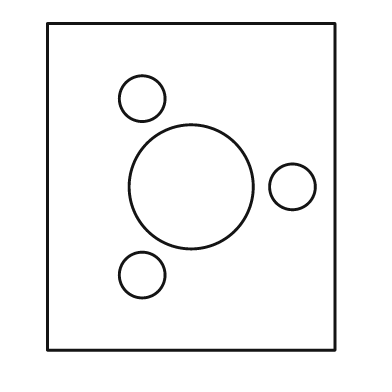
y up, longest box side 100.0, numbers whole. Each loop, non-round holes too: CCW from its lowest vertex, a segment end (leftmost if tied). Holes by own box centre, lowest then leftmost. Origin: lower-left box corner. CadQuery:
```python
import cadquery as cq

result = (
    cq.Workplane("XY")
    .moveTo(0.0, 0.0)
    .lineTo(88.0, 0.0)
    .lineTo(88.0, 100.0)
    .lineTo(0.0, 100.0)
    .close()
    .moveTo(29.0, 23.0)
    .circle(7.0)
    .moveTo(44.0, 50.0)
    .circle(19.0)
    .moveTo(75.0, 50.0)
    .circle(7.0)
    .moveTo(29.0, 77.0)
    .circle(7.0)
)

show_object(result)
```